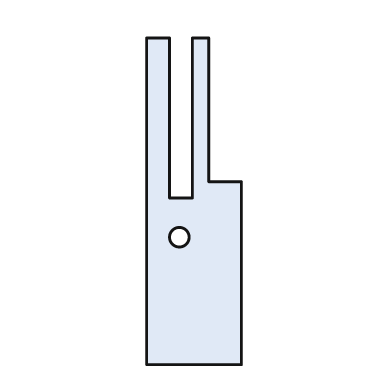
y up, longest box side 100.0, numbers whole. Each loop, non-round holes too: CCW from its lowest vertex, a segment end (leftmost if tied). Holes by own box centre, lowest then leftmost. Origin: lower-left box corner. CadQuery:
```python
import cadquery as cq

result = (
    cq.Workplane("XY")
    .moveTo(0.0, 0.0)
    .lineTo(29.0, 0.0)
    .lineTo(29.0, 56.0)
    .lineTo(19.0, 56.0)
    .lineTo(19.0, 100.0)
    .lineTo(14.0, 100.0)
    .lineTo(14.0, 51.0)
    .lineTo(7.0, 51.0)
    .lineTo(7.0, 100.0)
    .lineTo(0.0, 100.0)
    .close()
    .moveTo(10.0, 39.0)
    .circle(3.0)
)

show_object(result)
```